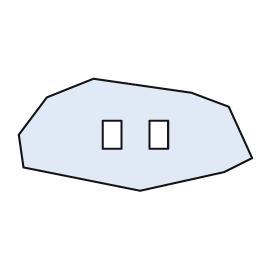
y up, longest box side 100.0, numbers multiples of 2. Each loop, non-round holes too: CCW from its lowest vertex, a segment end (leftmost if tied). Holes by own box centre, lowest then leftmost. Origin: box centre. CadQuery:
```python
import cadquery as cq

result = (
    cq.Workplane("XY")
    .moveTo(2.0, -24.0)
    .lineTo(38.0, -16.0)
    .lineTo(50.0, -10.0)
    .lineTo(40.0, 12.0)
    .lineTo(24.0, 18.0)
    .lineTo(-18.0, 24.0)
    .lineTo(-38.0, 16.0)
    .lineTo(-50.0, 0.0)
    .lineTo(-48.0, -14.0)
    .close()
    .moveTo(-14.0, -6.0)
    .lineTo(-6.0, -6.0)
    .lineTo(-6.0, 6.0)
    .lineTo(-14.0, 6.0)
    .close()
    .moveTo(6.0, -6.0)
    .lineTo(14.0, -6.0)
    .lineTo(14.0, 6.0)
    .lineTo(6.0, 6.0)
    .close()
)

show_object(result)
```